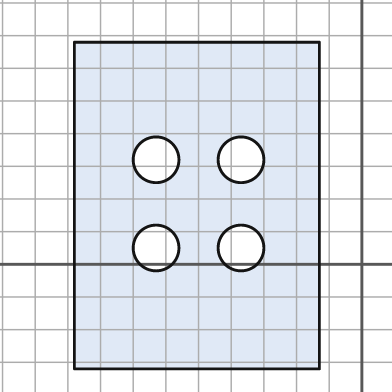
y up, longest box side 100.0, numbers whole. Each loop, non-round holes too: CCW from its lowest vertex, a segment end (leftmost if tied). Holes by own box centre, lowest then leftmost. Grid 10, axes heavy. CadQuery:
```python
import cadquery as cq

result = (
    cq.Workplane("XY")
    .moveTo(-88.0, -32.0)
    .lineTo(-13.0, -32.0)
    .lineTo(-13.0, 68.0)
    .lineTo(-88.0, 68.0)
    .close()
    .moveTo(-63.0, 5.0)
    .circle(7.0)
    .moveTo(-37.0, 5.0)
    .circle(7.0)
    .moveTo(-63.0, 32.0)
    .circle(7.0)
    .moveTo(-37.0, 32.0)
    .circle(7.0)
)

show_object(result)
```